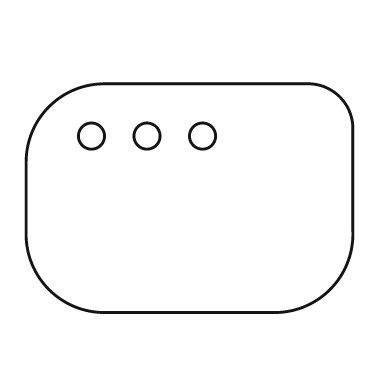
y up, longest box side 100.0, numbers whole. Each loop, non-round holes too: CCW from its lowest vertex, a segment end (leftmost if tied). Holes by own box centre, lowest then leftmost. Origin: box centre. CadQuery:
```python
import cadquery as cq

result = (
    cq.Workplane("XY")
    .moveTo(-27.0, -35.0)
    .lineTo(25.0, -35.0)
    .threePointArc((43.0, -28.0), (50.0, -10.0))
    .lineTo(50.0, 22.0)
    .threePointArc((46.0, 31.0), (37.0, 35.0))
    .lineTo(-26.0, 35.0)
    .threePointArc((-43.0, 28.0), (-50.0, 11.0))
    .lineTo(-50.0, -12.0)
    .threePointArc((-43.0, -28.0), (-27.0, -35.0))
    .close()
    .moveTo(-30.0, 19.0)
    .circle(4.0)
    .moveTo(-13.0, 19.0)
    .circle(4.0)
    .moveTo(4.0, 19.0)
    .circle(4.0)
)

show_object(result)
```